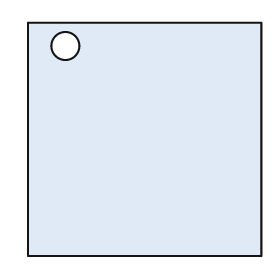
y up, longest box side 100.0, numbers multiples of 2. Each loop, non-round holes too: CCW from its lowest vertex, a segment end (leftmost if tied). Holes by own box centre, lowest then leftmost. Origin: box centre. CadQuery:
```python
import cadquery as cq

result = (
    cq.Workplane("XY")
    .moveTo(-50.0, -50.0)
    .lineTo(50.0, -50.0)
    .lineTo(50.0, 50.0)
    .lineTo(-50.0, 50.0)
    .close()
    .moveTo(-34.0, 40.0)
    .circle(6.0)
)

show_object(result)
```